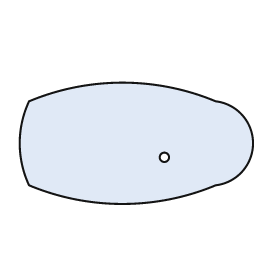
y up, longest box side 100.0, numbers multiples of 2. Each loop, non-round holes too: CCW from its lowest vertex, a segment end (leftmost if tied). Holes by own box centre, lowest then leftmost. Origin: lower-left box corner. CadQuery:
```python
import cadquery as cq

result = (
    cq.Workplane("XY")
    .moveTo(4.0, 8.0)
    .threePointArc((44.0, 0.0), (84.0, 8.0))
    .threePointArc((100.0, 26.0), (84.0, 44.0))
    .threePointArc((44.0, 52.0), (4.0, 44.0))
    .threePointArc((0.0, 26.0), (4.0, 8.0))
    .close()
    .moveTo(62.0, 20.0)
    .circle(2.0)
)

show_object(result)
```